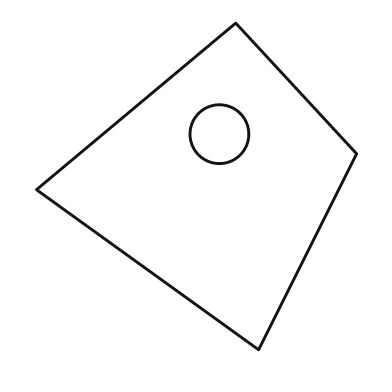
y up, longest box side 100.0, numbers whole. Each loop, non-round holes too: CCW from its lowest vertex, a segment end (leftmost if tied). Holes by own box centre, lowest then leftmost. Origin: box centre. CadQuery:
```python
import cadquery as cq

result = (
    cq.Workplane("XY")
    .moveTo(19.0, -50.0)
    .lineTo(49.0, 10.0)
    .lineTo(12.0, 50.0)
    .lineTo(-49.0, -1.0)
    .close()
    .moveTo(7.0, 16.0)
    .circle(9.0)
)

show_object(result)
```